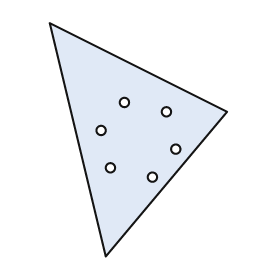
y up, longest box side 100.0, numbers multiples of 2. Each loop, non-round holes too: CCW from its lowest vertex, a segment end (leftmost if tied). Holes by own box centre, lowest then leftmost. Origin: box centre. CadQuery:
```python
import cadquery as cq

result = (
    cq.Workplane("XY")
    .moveTo(-14.0, -50.0)
    .lineTo(38.0, 12.0)
    .lineTo(-38.0, 50.0)
    .close()
    .moveTo(6.0, -16.0)
    .circle(2.0)
    .moveTo(-12.0, -12.0)
    .circle(2.0)
    .moveTo(16.0, -4.0)
    .circle(2.0)
    .moveTo(-16.0, 4.0)
    .circle(2.0)
    .moveTo(12.0, 12.0)
    .circle(2.0)
    .moveTo(-6.0, 16.0)
    .circle(2.0)
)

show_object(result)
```